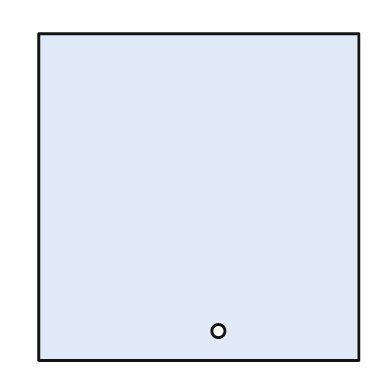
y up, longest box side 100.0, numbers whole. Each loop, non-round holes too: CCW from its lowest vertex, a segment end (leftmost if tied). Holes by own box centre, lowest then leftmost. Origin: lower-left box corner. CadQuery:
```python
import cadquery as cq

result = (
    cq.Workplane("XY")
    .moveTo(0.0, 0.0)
    .lineTo(98.0, 0.0)
    .lineTo(98.0, 100.0)
    .lineTo(0.0, 100.0)
    .close()
    .moveTo(55.0, 9.0)
    .circle(2.0)
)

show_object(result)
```